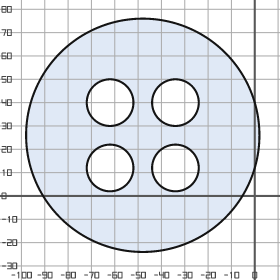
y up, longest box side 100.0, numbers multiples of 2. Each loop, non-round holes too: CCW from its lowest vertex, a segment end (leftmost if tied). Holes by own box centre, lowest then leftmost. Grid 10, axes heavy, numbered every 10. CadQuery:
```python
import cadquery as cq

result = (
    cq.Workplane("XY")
    .moveTo(-48.0, 26.0)
    .circle(50.0)
    .moveTo(-62.0, 12.0)
    .circle(10.0)
    .moveTo(-34.0, 12.0)
    .circle(10.0)
    .moveTo(-62.0, 40.0)
    .circle(10.0)
    .moveTo(-34.0, 40.0)
    .circle(10.0)
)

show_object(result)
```